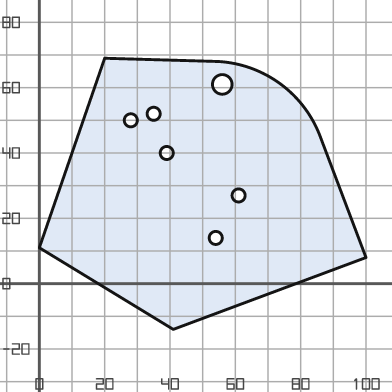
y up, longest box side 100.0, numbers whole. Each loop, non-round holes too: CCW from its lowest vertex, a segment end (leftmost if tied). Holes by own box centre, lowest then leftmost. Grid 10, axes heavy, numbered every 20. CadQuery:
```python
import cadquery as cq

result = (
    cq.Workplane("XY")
    .moveTo(41.0, -14.0)
    .lineTo(100.0, 8.0)
    .lineTo(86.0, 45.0)
    .threePointArc((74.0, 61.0), (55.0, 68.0))
    .lineTo(20.0, 69.0)
    .lineTo(0.0, 11.0)
    .close()
    .moveTo(54.0, 14.0)
    .circle(2.0)
    .moveTo(61.0, 27.0)
    .circle(2.0)
    .moveTo(39.0, 40.0)
    .circle(2.0)
    .moveTo(28.0, 50.0)
    .circle(2.0)
    .moveTo(35.0, 52.0)
    .circle(2.0)
    .moveTo(56.0, 61.0)
    .circle(3.0)
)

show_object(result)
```